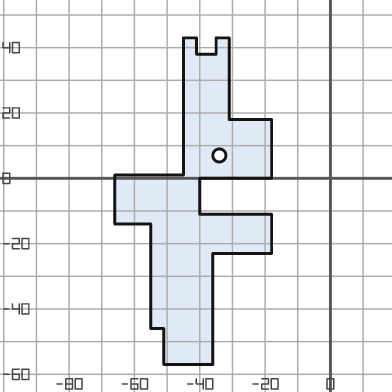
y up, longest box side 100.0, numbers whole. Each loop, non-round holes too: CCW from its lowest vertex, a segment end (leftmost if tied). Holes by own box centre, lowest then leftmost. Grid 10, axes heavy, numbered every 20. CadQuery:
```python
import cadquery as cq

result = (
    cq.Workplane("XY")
    .moveTo(-51.0, -57.0)
    .lineTo(-36.0, -57.0)
    .lineTo(-36.0, -23.0)
    .lineTo(-18.0, -23.0)
    .lineTo(-18.0, -11.0)
    .lineTo(-40.0, -11.0)
    .lineTo(-40.0, 0.0)
    .lineTo(-18.0, 0.0)
    .lineTo(-18.0, 18.0)
    .lineTo(-31.0, 18.0)
    .lineTo(-31.0, 43.0)
    .lineTo(-35.0, 43.0)
    .lineTo(-35.0, 38.0)
    .lineTo(-41.0, 38.0)
    .lineTo(-41.0, 43.0)
    .lineTo(-45.0, 43.0)
    .lineTo(-45.0, 1.0)
    .lineTo(-66.0, 1.0)
    .lineTo(-66.0, -14.0)
    .lineTo(-55.0, -14.0)
    .lineTo(-55.0, -46.0)
    .lineTo(-51.0, -46.0)
    .close()
    .moveTo(-34.0, 7.0)
    .circle(2.0)
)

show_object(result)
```